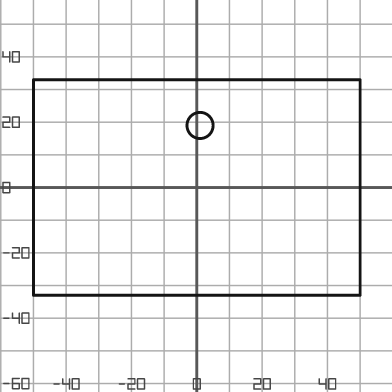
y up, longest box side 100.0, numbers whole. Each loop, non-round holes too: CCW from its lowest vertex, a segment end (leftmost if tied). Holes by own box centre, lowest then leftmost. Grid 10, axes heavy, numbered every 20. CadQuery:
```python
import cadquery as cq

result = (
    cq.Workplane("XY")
    .moveTo(-50.0, -33.0)
    .lineTo(50.0, -33.0)
    .lineTo(50.0, 33.0)
    .lineTo(-50.0, 33.0)
    .close()
    .moveTo(1.0, 19.0)
    .circle(4.0)
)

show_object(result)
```